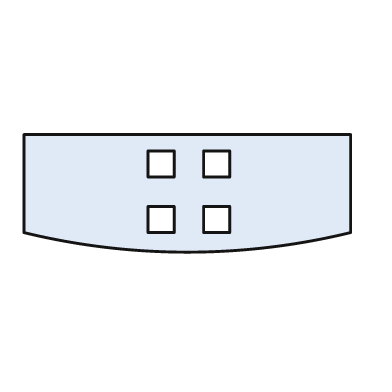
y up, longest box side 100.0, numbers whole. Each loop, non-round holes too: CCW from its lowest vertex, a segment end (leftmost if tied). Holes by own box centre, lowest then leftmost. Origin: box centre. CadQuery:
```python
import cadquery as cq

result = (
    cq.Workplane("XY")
    .moveTo(-50.0, -12.0)
    .threePointArc((0.0, -18.0), (50.0, -12.0))
    .lineTo(50.0, 18.0)
    .lineTo(-50.0, 18.0)
    .close()
    .moveTo(-12.0, -12.0)
    .lineTo(-4.0, -12.0)
    .lineTo(-4.0, -4.0)
    .lineTo(-12.0, -4.0)
    .close()
    .moveTo(5.0, -12.0)
    .lineTo(13.0, -12.0)
    .lineTo(13.0, -4.0)
    .lineTo(5.0, -4.0)
    .close()
    .moveTo(-12.0, 5.0)
    .lineTo(-4.0, 5.0)
    .lineTo(-4.0, 13.0)
    .lineTo(-12.0, 13.0)
    .close()
    .moveTo(5.0, 5.0)
    .lineTo(13.0, 5.0)
    .lineTo(13.0, 13.0)
    .lineTo(5.0, 13.0)
    .close()
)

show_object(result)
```